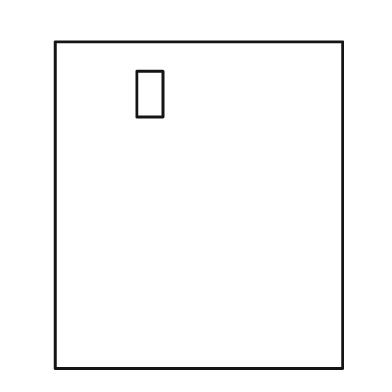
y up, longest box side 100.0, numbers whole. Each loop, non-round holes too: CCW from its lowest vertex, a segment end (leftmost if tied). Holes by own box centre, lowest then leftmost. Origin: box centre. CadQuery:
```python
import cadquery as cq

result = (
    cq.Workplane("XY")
    .moveTo(-44.0, -50.0)
    .lineTo(44.0, -50.0)
    .lineTo(44.0, 50.0)
    .lineTo(-44.0, 50.0)
    .close()
    .moveTo(-19.0, 27.0)
    .lineTo(-11.0, 27.0)
    .lineTo(-11.0, 41.0)
    .lineTo(-19.0, 41.0)
    .close()
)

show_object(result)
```